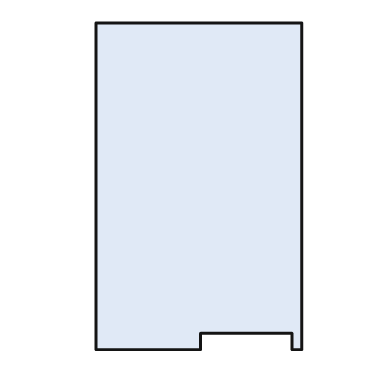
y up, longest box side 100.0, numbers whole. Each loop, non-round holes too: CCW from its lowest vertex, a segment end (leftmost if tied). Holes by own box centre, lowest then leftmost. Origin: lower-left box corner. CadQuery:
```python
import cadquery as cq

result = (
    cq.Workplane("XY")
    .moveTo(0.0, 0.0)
    .lineTo(32.0, 0.0)
    .lineTo(32.0, 5.0)
    .lineTo(60.0, 5.0)
    .lineTo(60.0, 0.0)
    .lineTo(63.0, 0.0)
    .lineTo(63.0, 100.0)
    .lineTo(0.0, 100.0)
    .close()
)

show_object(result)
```